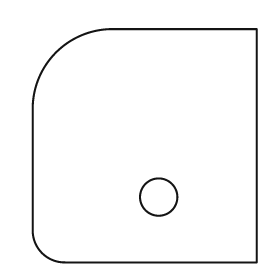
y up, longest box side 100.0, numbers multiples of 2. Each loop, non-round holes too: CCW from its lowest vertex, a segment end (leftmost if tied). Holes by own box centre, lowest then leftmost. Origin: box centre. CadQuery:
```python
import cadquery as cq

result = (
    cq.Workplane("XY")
    .moveTo(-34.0, -50.0)
    .lineTo(48.0, -50.0)
    .lineTo(48.0, 50.0)
    .lineTo(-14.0, 50.0)
    .threePointArc((-38.0, 40.0), (-48.0, 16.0))
    .lineTo(-48.0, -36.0)
    .threePointArc((-44.0, -46.0), (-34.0, -50.0))
    .close()
    .moveTo(6.0, -22.0)
    .circle(8.0)
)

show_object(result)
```